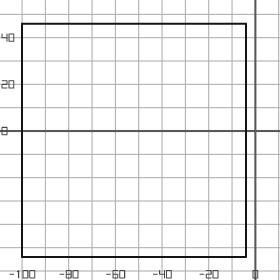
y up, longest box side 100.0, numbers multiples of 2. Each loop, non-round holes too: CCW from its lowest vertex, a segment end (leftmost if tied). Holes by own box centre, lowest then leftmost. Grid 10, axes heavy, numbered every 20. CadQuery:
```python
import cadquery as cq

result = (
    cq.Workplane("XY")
    .moveTo(-100.0, -54.0)
    .lineTo(-4.0, -54.0)
    .lineTo(-4.0, 46.0)
    .lineTo(-100.0, 46.0)
    .close()
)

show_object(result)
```